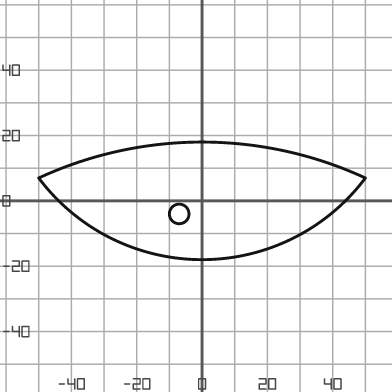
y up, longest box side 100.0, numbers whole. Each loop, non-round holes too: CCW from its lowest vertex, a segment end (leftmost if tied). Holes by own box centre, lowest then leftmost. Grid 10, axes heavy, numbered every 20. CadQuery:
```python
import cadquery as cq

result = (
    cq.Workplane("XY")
    .moveTo(-50.0, 7.0)
    .threePointArc((0.0, -18.0), (50.0, 7.0))
    .threePointArc((0.0, 18.0), (-50.0, 7.0))
    .close()
    .moveTo(-7.0, -4.0)
    .circle(3.0)
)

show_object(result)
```